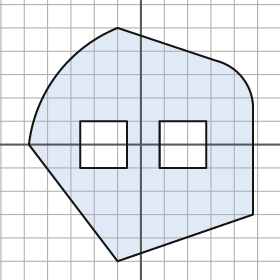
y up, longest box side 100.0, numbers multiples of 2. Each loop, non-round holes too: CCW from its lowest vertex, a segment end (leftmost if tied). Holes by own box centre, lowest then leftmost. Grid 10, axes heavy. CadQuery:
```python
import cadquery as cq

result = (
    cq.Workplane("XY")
    .moveTo(-10.0, -50.0)
    .lineTo(48.0, -30.0)
    .lineTo(48.0, 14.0)
    .threePointArc((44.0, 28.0), (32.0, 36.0))
    .lineTo(-10.0, 50.0)
    .threePointArc((-36.0, 30.0), (-48.0, 0.0))
    .close()
    .moveTo(-26.0, -10.0)
    .lineTo(-6.0, -10.0)
    .lineTo(-6.0, 10.0)
    .lineTo(-26.0, 10.0)
    .close()
    .moveTo(8.0, -10.0)
    .lineTo(28.0, -10.0)
    .lineTo(28.0, 10.0)
    .lineTo(8.0, 10.0)
    .close()
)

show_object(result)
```